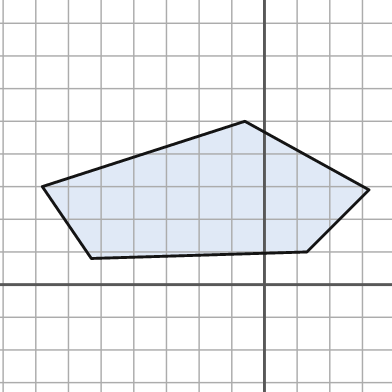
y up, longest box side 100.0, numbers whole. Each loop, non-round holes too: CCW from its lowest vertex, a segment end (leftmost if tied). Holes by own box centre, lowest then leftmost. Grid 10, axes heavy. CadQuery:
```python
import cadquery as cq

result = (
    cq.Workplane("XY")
    .moveTo(-53.0, 8.0)
    .lineTo(13.0, 10.0)
    .lineTo(32.0, 29.0)
    .lineTo(-6.0, 50.0)
    .lineTo(-68.0, 30.0)
    .close()
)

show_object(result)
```